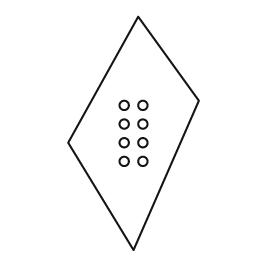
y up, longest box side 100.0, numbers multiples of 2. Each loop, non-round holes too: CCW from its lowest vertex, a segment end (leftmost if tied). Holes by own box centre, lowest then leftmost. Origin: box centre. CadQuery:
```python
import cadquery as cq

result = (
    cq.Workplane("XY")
    .moveTo(0.0, -50.0)
    .lineTo(28.0, 14.0)
    .lineTo(2.0, 50.0)
    .lineTo(-28.0, -4.0)
    .close()
    .moveTo(-4.0, -12.0)
    .circle(2.0)
    .moveTo(4.0, -12.0)
    .circle(2.0)
    .moveTo(-4.0, -4.0)
    .circle(2.0)
    .moveTo(4.0, -4.0)
    .circle(2.0)
    .moveTo(-4.0, 4.0)
    .circle(2.0)
    .moveTo(4.0, 4.0)
    .circle(2.0)
    .moveTo(-4.0, 12.0)
    .circle(2.0)
    .moveTo(4.0, 12.0)
    .circle(2.0)
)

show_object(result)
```